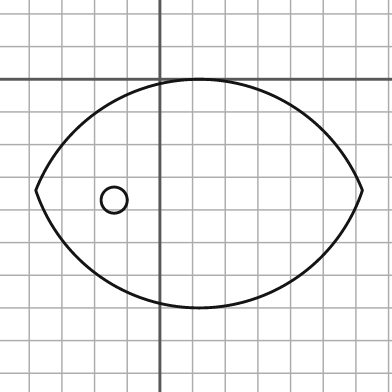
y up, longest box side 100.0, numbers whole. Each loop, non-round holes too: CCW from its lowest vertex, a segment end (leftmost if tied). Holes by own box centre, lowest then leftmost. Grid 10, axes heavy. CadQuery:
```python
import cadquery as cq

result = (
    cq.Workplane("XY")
    .moveTo(-38.0, -34.0)
    .threePointArc((12.0, -70.0), (62.0, -34.0))
    .threePointArc((12.0, 0.0), (-38.0, -34.0))
    .close()
    .moveTo(-14.0, -37.0)
    .circle(4.0)
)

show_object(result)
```